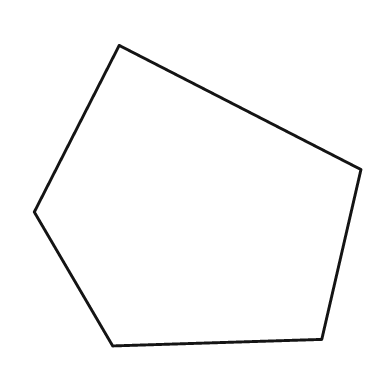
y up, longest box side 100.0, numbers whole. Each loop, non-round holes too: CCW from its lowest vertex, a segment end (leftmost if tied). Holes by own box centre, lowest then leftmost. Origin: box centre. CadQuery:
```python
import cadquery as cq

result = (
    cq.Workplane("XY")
    .moveTo(-26.0, -46.0)
    .lineTo(38.0, -44.0)
    .lineTo(50.0, 8.0)
    .lineTo(-24.0, 46.0)
    .lineTo(-50.0, -5.0)
    .close()
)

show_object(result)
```